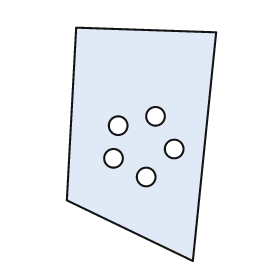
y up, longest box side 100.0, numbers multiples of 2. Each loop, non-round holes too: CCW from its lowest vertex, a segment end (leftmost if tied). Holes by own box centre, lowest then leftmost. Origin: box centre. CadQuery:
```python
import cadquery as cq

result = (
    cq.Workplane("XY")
    .moveTo(22.0, -50.0)
    .lineTo(32.0, 48.0)
    .lineTo(-28.0, 50.0)
    .lineTo(-32.0, -24.0)
    .close()
    .moveTo(2.0, -14.0)
    .circle(4.0)
    .moveTo(-12.0, -6.0)
    .circle(4.0)
    .moveTo(14.0, -2.0)
    .circle(4.0)
    .moveTo(-10.0, 8.0)
    .circle(4.0)
    .moveTo(6.0, 12.0)
    .circle(4.0)
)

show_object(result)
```